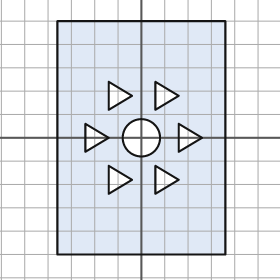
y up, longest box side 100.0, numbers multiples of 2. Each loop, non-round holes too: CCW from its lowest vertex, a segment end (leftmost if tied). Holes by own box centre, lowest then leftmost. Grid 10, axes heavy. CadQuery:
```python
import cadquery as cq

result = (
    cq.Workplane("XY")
    .moveTo(-36.0, -50.0)
    .lineTo(36.0, -50.0)
    .lineTo(36.0, 50.0)
    .lineTo(-36.0, 50.0)
    .close()
    .moveTo(-14.0, -24.0)
    .lineTo(-4.0, -18.0)
    .lineTo(-14.0, -12.0)
    .close()
    .moveTo(6.0, -24.0)
    .lineTo(16.0, -18.0)
    .lineTo(6.0, -12.0)
    .close()
    .moveTo(-24.0, -6.0)
    .lineTo(-14.0, 0.0)
    .lineTo(-24.0, 6.0)
    .close()
    .moveTo(0.0, 0.0)
    .circle(8.0)
    .moveTo(16.0, -6.0)
    .lineTo(26.0, 0.0)
    .lineTo(16.0, 6.0)
    .close()
    .moveTo(-14.0, 12.0)
    .lineTo(-4.0, 18.0)
    .lineTo(-14.0, 24.0)
    .close()
    .moveTo(6.0, 12.0)
    .lineTo(16.0, 18.0)
    .lineTo(6.0, 24.0)
    .close()
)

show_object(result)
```